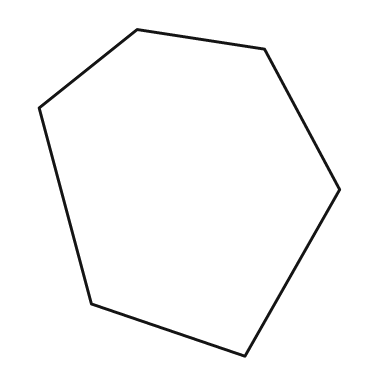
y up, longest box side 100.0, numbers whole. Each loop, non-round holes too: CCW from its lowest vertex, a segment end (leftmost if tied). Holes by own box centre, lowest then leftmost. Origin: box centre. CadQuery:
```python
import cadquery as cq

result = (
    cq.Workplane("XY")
    .moveTo(17.0, -50.0)
    .lineTo(46.0, 1.0)
    .lineTo(23.0, 44.0)
    .lineTo(-16.0, 50.0)
    .lineTo(-46.0, 26.0)
    .lineTo(-30.0, -34.0)
    .close()
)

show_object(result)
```